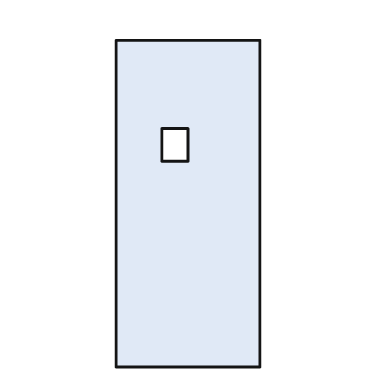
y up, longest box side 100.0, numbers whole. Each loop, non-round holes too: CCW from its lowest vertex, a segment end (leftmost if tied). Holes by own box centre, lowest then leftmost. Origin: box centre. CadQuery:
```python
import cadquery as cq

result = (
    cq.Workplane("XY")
    .moveTo(-22.0, -50.0)
    .lineTo(22.0, -50.0)
    .lineTo(22.0, 50.0)
    .lineTo(-22.0, 50.0)
    .close()
    .moveTo(-8.0, 13.0)
    .lineTo(0.0, 13.0)
    .lineTo(0.0, 23.0)
    .lineTo(-8.0, 23.0)
    .close()
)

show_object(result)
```